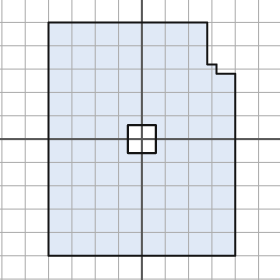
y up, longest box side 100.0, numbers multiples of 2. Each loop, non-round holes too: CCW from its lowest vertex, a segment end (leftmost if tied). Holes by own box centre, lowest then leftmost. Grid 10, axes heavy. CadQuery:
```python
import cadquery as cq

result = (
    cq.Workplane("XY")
    .moveTo(-40.0, -50.0)
    .lineTo(40.0, -50.0)
    .lineTo(40.0, 28.0)
    .lineTo(32.0, 28.0)
    .lineTo(32.0, 32.0)
    .lineTo(28.0, 32.0)
    .lineTo(28.0, 50.0)
    .lineTo(-40.0, 50.0)
    .close()
    .moveTo(-6.0, -6.0)
    .lineTo(6.0, -6.0)
    .lineTo(6.0, 6.0)
    .lineTo(-6.0, 6.0)
    .close()
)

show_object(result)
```